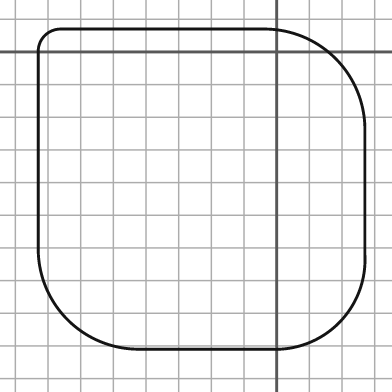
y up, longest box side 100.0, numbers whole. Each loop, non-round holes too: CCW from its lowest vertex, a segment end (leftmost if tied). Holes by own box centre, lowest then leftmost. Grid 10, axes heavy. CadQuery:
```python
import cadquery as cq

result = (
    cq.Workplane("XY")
    .moveTo(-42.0, -91.0)
    .lineTo(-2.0, -91.0)
    .threePointArc((19.0, -83.0), (27.0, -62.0))
    .lineTo(27.0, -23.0)
    .threePointArc((18.0, -2.0), (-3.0, 7.0))
    .lineTo(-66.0, 7.0)
    .threePointArc((-71.0, 5.0), (-73.0, 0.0))
    .lineTo(-73.0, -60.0)
    .threePointArc((-64.0, -82.0), (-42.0, -91.0))
    .close()
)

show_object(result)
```